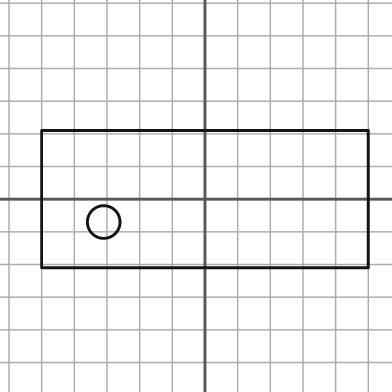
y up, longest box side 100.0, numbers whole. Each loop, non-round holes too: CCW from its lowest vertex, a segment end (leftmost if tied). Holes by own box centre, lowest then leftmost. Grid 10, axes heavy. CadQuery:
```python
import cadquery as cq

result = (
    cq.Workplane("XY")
    .moveTo(-50.0, -21.0)
    .lineTo(50.0, -21.0)
    .lineTo(50.0, 21.0)
    .lineTo(-50.0, 21.0)
    .close()
    .moveTo(-31.0, -7.0)
    .circle(5.0)
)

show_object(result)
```